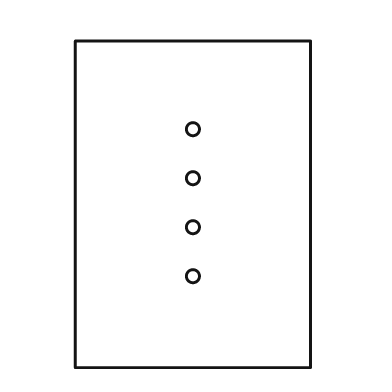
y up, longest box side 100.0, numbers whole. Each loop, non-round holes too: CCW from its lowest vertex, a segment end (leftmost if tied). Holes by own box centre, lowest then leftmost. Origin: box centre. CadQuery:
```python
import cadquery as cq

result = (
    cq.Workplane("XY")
    .moveTo(-36.0, -50.0)
    .lineTo(36.0, -50.0)
    .lineTo(36.0, 50.0)
    .lineTo(-36.0, 50.0)
    .close()
    .moveTo(0.0, -22.0)
    .circle(2.0)
    .moveTo(0.0, -7.0)
    .circle(2.0)
    .moveTo(0.0, 8.0)
    .circle(2.0)
    .moveTo(0.0, 23.0)
    .circle(2.0)
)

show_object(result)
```